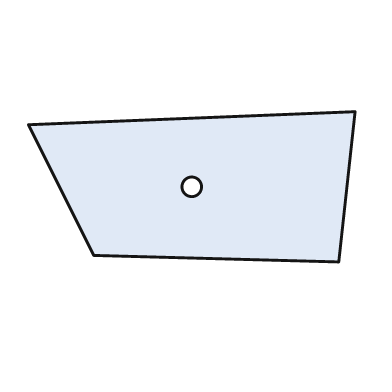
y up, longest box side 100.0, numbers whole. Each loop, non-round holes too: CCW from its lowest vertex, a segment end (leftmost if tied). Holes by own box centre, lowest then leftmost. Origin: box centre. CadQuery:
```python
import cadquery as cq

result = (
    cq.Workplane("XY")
    .moveTo(45.0, -23.0)
    .lineTo(50.0, 23.0)
    .lineTo(-50.0, 19.0)
    .lineTo(-30.0, -21.0)
    .close()
    .moveTo(0.0, 0.0)
    .circle(3.0)
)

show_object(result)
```